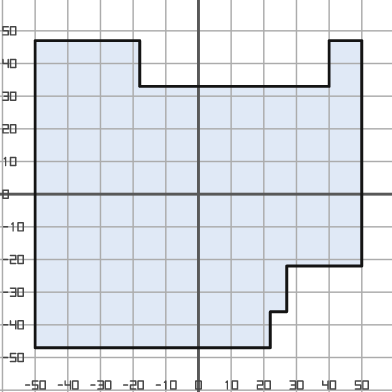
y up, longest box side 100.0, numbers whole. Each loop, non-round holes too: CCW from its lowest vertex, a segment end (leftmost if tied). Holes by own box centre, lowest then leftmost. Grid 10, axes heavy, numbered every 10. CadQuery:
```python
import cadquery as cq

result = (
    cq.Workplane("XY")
    .moveTo(-50.0, -47.0)
    .lineTo(22.0, -47.0)
    .lineTo(22.0, -36.0)
    .lineTo(27.0, -36.0)
    .lineTo(27.0, -22.0)
    .lineTo(50.0, -22.0)
    .lineTo(50.0, 47.0)
    .lineTo(40.0, 47.0)
    .lineTo(40.0, 33.0)
    .lineTo(-18.0, 33.0)
    .lineTo(-18.0, 47.0)
    .lineTo(-50.0, 47.0)
    .close()
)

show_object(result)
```